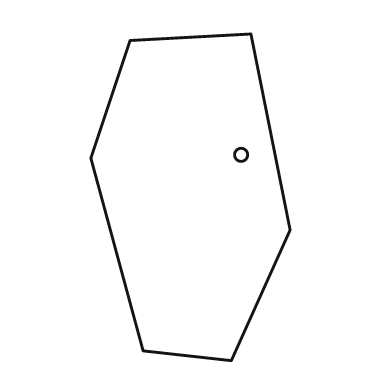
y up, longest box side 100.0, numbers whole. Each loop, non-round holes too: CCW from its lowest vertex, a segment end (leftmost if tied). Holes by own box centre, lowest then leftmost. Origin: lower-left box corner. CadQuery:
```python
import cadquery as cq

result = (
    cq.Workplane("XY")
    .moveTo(43.0, 0.0)
    .lineTo(61.0, 40.0)
    .lineTo(49.0, 100.0)
    .lineTo(12.0, 98.0)
    .lineTo(0.0, 62.0)
    .lineTo(16.0, 3.0)
    .close()
    .moveTo(46.0, 63.0)
    .circle(2.0)
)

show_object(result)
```